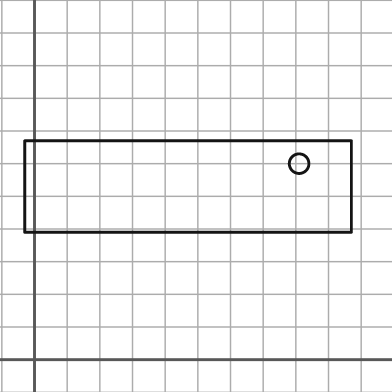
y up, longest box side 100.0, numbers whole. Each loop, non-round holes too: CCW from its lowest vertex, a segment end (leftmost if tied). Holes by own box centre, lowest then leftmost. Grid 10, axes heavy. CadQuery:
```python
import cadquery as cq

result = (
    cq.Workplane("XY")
    .moveTo(-3.0, 39.0)
    .lineTo(97.0, 39.0)
    .lineTo(97.0, 67.0)
    .lineTo(-3.0, 67.0)
    .close()
    .moveTo(81.0, 60.0)
    .circle(3.0)
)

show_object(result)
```